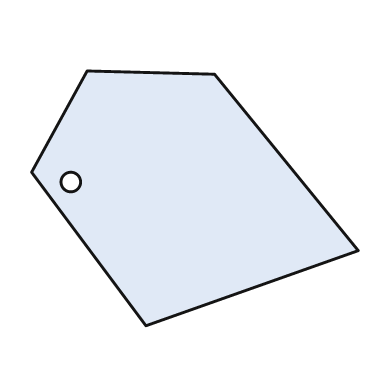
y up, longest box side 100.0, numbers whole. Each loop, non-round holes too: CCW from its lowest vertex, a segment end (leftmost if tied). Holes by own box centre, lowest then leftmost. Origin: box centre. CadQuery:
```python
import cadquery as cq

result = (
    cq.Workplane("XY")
    .moveTo(-15.0, -39.0)
    .lineTo(50.0, -16.0)
    .lineTo(6.0, 38.0)
    .lineTo(-33.0, 39.0)
    .lineTo(-50.0, 8.0)
    .close()
    .moveTo(-38.0, 5.0)
    .circle(3.0)
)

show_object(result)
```